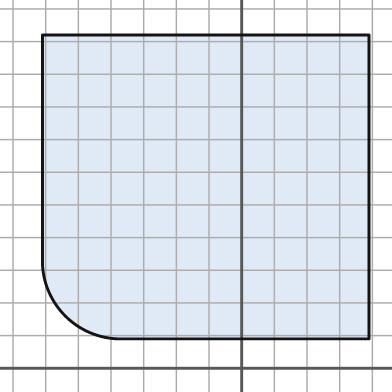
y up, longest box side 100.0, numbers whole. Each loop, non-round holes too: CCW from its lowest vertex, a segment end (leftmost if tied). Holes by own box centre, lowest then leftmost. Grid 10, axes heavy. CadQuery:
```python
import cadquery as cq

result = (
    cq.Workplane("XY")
    .moveTo(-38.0, 9.0)
    .lineTo(39.0, 9.0)
    .lineTo(39.0, 102.0)
    .lineTo(-61.0, 102.0)
    .lineTo(-61.0, 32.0)
    .threePointArc((-54.0, 16.0), (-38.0, 9.0))
    .close()
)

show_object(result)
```